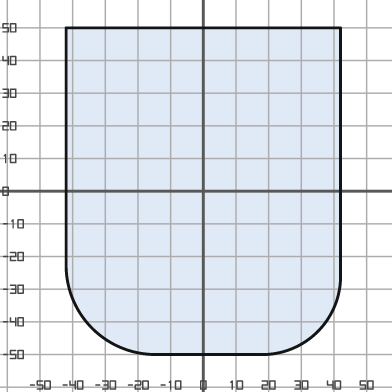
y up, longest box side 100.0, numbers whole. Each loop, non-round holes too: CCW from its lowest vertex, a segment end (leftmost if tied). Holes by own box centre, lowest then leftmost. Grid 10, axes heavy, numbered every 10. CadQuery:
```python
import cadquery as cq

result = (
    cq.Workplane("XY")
    .moveTo(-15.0, -50.0)
    .lineTo(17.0, -50.0)
    .threePointArc((35.0, -43.0), (42.0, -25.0))
    .lineTo(42.0, 50.0)
    .lineTo(-42.0, 50.0)
    .lineTo(-42.0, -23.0)
    .threePointArc((-34.0, -42.0), (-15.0, -50.0))
    .close()
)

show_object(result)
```